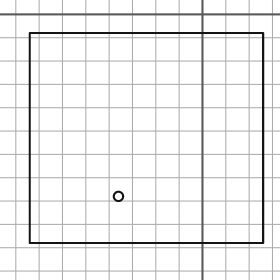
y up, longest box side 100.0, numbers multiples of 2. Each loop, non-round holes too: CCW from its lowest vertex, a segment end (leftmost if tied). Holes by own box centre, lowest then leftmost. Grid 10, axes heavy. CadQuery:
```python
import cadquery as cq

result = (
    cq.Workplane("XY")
    .moveTo(-74.0, -98.0)
    .lineTo(26.0, -98.0)
    .lineTo(26.0, -8.0)
    .lineTo(-74.0, -8.0)
    .close()
    .moveTo(-36.0, -78.0)
    .circle(2.0)
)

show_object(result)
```